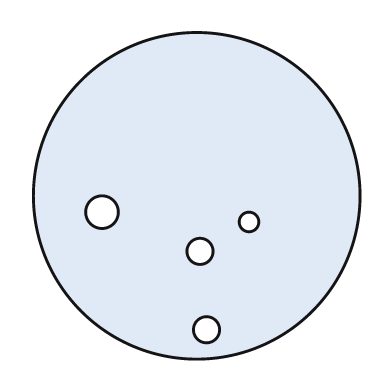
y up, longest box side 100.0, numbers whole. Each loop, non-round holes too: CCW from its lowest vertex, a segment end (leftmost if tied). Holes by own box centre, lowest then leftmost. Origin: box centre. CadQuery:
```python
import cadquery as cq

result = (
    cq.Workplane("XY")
    .moveTo(0.0, 0.0)
    .circle(50.0)
    .moveTo(3.0, -41.0)
    .circle(4.0)
    .moveTo(1.0, -17.0)
    .circle(4.0)
    .moveTo(16.0, -8.0)
    .circle(3.0)
    .moveTo(-29.0, -5.0)
    .circle(5.0)
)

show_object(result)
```